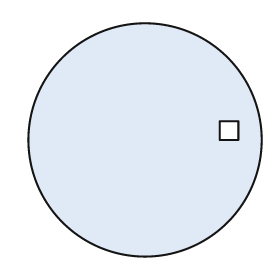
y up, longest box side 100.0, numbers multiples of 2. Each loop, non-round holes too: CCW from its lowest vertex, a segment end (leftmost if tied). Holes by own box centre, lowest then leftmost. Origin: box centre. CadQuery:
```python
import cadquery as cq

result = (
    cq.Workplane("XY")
    .moveTo(0.0, 0.0)
    .circle(50.0)
    .moveTo(32.0, 0.0)
    .lineTo(40.0, 0.0)
    .lineTo(40.0, 8.0)
    .lineTo(32.0, 8.0)
    .close()
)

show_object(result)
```